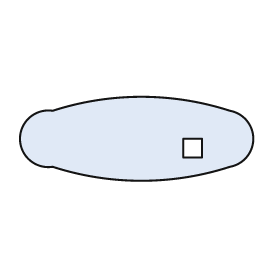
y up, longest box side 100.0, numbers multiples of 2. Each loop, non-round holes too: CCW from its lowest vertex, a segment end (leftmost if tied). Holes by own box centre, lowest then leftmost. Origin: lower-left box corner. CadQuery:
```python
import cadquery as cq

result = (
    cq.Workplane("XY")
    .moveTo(14.0, 6.0)
    .threePointArc((52.0, 0.0), (90.0, 6.0))
    .threePointArc((100.0, 18.0), (90.0, 30.0))
    .threePointArc((52.0, 36.0), (14.0, 30.0))
    .threePointArc((0.0, 18.0), (14.0, 6.0))
    .close()
    .moveTo(70.0, 10.0)
    .lineTo(78.0, 10.0)
    .lineTo(78.0, 18.0)
    .lineTo(70.0, 18.0)
    .close()
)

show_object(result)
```